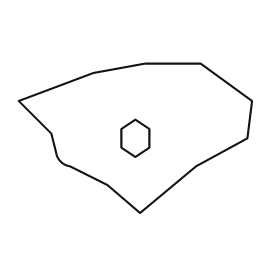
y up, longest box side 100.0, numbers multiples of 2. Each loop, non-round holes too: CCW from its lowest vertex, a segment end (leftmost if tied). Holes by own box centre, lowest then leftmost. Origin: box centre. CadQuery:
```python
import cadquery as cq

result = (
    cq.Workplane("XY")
    .moveTo(2.0, -32.0)
    .lineTo(26.0, -12.0)
    .lineTo(48.0, 0.0)
    .lineTo(50.0, 16.0)
    .lineTo(28.0, 32.0)
    .lineTo(4.0, 32.0)
    .lineTo(-18.0, 28.0)
    .lineTo(-50.0, 16.0)
    .lineTo(-36.0, 2.0)
    .lineTo(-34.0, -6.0)
    .threePointArc((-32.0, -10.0), (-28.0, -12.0))
    .lineTo(-12.0, -20.0)
    .close()
    .moveTo(0.0, -8.0)
    .lineTo(6.0, -4.0)
    .lineTo(6.0, 4.0)
    .lineTo(0.0, 8.0)
    .lineTo(-6.0, 4.0)
    .lineTo(-6.0, -4.0)
    .close()
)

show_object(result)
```